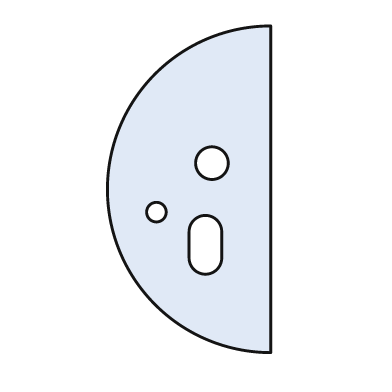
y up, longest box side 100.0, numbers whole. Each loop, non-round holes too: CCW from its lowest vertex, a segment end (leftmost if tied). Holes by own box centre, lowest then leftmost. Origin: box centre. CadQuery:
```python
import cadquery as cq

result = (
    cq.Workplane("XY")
    .moveTo(25.0, -50.0)
    .lineTo(25.0, 50.0)
    .threePointArc((-25.0, 0.0), (25.0, -50.0))
    .close()
    .moveTo(0.0, -21.0)
    .threePointArc((5.0, -26.0), (10.0, -21.0))
    .lineTo(10.0, -13.0)
    .threePointArc((5.0, -8.0), (0.0, -13.0))
    .close()
    .moveTo(-10.0, -7.0)
    .circle(3.0)
    .moveTo(7.0, 8.0)
    .circle(5.0)
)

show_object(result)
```